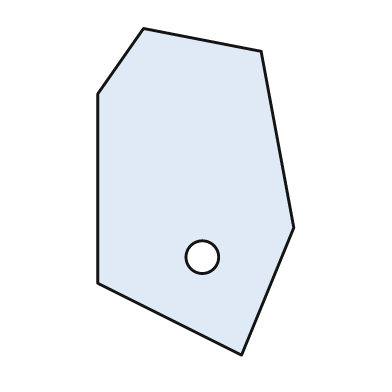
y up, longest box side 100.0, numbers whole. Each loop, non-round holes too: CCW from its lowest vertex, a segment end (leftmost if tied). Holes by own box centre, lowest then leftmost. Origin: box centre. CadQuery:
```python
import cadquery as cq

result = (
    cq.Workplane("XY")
    .moveTo(14.0, -50.0)
    .lineTo(30.0, -11.0)
    .lineTo(20.0, 43.0)
    .lineTo(-16.0, 50.0)
    .lineTo(-30.0, 30.0)
    .lineTo(-30.0, -28.0)
    .close()
    .moveTo(2.0, -20.0)
    .circle(5.0)
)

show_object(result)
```